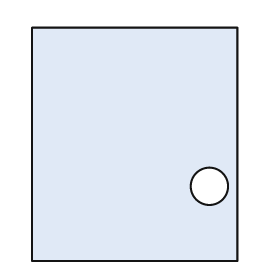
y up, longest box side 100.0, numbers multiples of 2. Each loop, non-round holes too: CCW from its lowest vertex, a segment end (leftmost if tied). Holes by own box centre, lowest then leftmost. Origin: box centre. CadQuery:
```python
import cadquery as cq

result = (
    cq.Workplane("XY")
    .moveTo(-44.0, -50.0)
    .lineTo(44.0, -50.0)
    .lineTo(44.0, 50.0)
    .lineTo(-44.0, 50.0)
    .close()
    .moveTo(32.0, -18.0)
    .circle(8.0)
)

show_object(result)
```